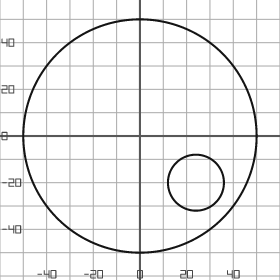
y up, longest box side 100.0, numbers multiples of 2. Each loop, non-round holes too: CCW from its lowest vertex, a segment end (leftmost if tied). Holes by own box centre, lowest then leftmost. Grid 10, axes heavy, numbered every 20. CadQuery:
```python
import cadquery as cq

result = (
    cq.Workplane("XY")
    .moveTo(0.0, 0.0)
    .circle(50.0)
    .moveTo(24.0, -20.0)
    .circle(12.0)
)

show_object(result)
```